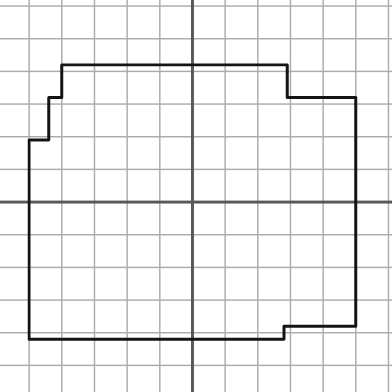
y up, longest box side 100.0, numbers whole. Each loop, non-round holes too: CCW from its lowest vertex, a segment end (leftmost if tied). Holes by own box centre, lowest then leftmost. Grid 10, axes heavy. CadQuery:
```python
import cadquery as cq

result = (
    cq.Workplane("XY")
    .moveTo(-50.0, -42.0)
    .lineTo(28.0, -42.0)
    .lineTo(28.0, -38.0)
    .lineTo(50.0, -38.0)
    .lineTo(50.0, 32.0)
    .lineTo(29.0, 32.0)
    .lineTo(29.0, 42.0)
    .lineTo(-40.0, 42.0)
    .lineTo(-40.0, 32.0)
    .lineTo(-44.0, 32.0)
    .lineTo(-44.0, 19.0)
    .lineTo(-50.0, 19.0)
    .close()
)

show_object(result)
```